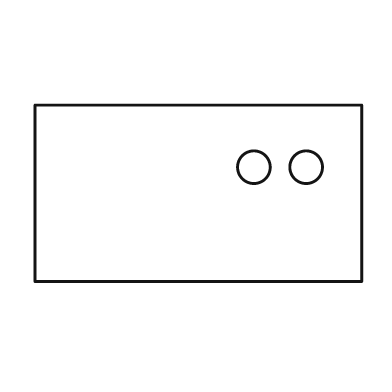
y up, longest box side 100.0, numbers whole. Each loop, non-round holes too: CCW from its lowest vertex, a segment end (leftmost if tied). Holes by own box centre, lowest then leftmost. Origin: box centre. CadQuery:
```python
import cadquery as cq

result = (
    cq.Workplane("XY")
    .moveTo(-50.0, -27.0)
    .lineTo(50.0, -27.0)
    .lineTo(50.0, 27.0)
    .lineTo(-50.0, 27.0)
    .close()
    .moveTo(17.0, 8.0)
    .circle(5.0)
    .moveTo(33.0, 8.0)
    .circle(5.0)
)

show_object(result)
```